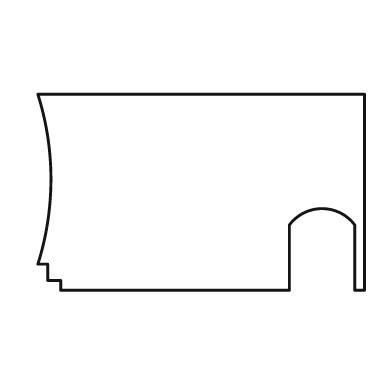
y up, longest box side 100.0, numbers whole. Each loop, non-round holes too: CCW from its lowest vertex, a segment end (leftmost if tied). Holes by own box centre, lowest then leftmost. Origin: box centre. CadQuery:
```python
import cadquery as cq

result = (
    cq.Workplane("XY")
    .moveTo(-43.0, -30.0)
    .lineTo(27.0, -30.0)
    .lineTo(27.0, -10.0)
    .threePointArc((37.0, -5.0), (47.0, -10.0))
    .lineTo(47.0, -30.0)
    .lineTo(50.0, -30.0)
    .lineTo(50.0, 30.0)
    .lineTo(-50.0, 30.0)
    .threePointArc((-46.0, 4.0), (-50.0, -22.0))
    .lineTo(-47.0, -22.0)
    .lineTo(-47.0, -27.0)
    .lineTo(-43.0, -27.0)
    .close()
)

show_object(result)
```